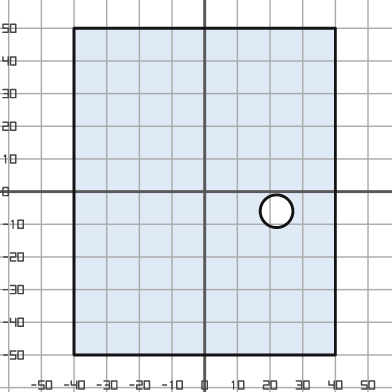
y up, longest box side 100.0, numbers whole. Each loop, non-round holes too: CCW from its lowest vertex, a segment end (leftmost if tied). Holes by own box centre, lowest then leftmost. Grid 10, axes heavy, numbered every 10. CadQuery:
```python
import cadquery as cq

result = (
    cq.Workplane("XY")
    .moveTo(-40.0, -50.0)
    .lineTo(40.0, -50.0)
    .lineTo(40.0, 50.0)
    .lineTo(-40.0, 50.0)
    .close()
    .moveTo(22.0, -6.0)
    .circle(5.0)
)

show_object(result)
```